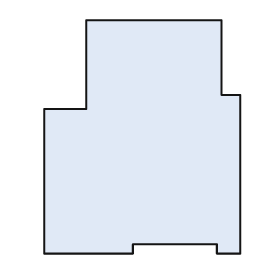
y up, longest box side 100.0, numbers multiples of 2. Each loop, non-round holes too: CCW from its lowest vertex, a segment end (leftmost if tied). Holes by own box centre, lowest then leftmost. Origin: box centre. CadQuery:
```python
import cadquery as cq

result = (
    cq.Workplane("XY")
    .moveTo(-42.0, -50.0)
    .lineTo(-4.0, -50.0)
    .lineTo(-4.0, -46.0)
    .lineTo(32.0, -46.0)
    .lineTo(32.0, -50.0)
    .lineTo(42.0, -50.0)
    .lineTo(42.0, 18.0)
    .lineTo(34.0, 18.0)
    .lineTo(34.0, 50.0)
    .lineTo(-24.0, 50.0)
    .lineTo(-24.0, 12.0)
    .lineTo(-42.0, 12.0)
    .close()
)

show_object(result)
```